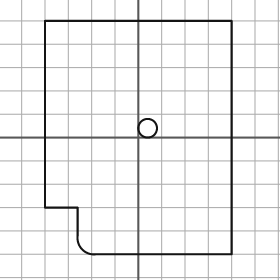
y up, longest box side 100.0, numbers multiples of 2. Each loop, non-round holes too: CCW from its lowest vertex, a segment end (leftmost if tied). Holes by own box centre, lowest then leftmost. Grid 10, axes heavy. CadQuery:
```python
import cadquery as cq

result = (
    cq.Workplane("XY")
    .moveTo(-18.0, -50.0)
    .lineTo(40.0, -50.0)
    .lineTo(40.0, 50.0)
    .lineTo(-40.0, 50.0)
    .lineTo(-40.0, -30.0)
    .lineTo(-26.0, -30.0)
    .lineTo(-26.0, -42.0)
    .threePointArc((-24.0, -48.0), (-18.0, -50.0))
    .close()
    .moveTo(4.0, 4.0)
    .circle(4.0)
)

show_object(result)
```